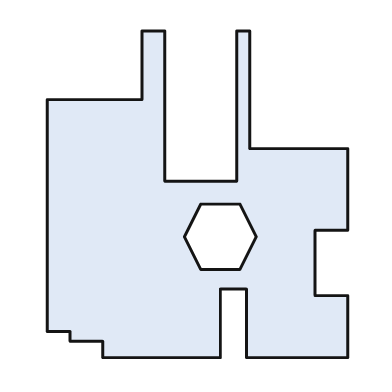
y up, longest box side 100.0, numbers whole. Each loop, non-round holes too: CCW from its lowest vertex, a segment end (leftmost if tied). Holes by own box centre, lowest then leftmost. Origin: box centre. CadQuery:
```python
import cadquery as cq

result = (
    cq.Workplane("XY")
    .moveTo(-29.0, -50.0)
    .lineTo(7.0, -50.0)
    .lineTo(7.0, -29.0)
    .lineTo(15.0, -29.0)
    .lineTo(15.0, -50.0)
    .lineTo(46.0, -50.0)
    .lineTo(46.0, -31.0)
    .lineTo(36.0, -31.0)
    .lineTo(36.0, -11.0)
    .lineTo(46.0, -11.0)
    .lineTo(46.0, 14.0)
    .lineTo(16.0, 14.0)
    .lineTo(16.0, 50.0)
    .lineTo(12.0, 50.0)
    .lineTo(12.0, 4.0)
    .lineTo(-10.0, 4.0)
    .lineTo(-10.0, 50.0)
    .lineTo(-17.0, 50.0)
    .lineTo(-17.0, 29.0)
    .lineTo(-46.0, 29.0)
    .lineTo(-46.0, -42.0)
    .lineTo(-39.0, -42.0)
    .lineTo(-39.0, -45.0)
    .lineTo(-29.0, -45.0)
    .close()
    .moveTo(1.0, -23.0)
    .lineTo(13.0, -23.0)
    .lineTo(18.0, -13.0)
    .lineTo(13.0, -3.0)
    .lineTo(1.0, -3.0)
    .lineTo(-4.0, -13.0)
    .close()
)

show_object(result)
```